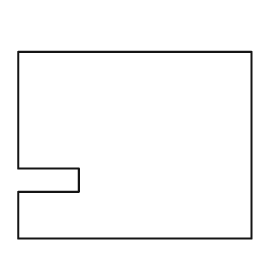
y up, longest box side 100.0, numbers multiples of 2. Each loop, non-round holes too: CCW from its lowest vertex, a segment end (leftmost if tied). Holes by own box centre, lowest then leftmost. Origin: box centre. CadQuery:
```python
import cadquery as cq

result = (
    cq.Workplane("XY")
    .moveTo(-50.0, -40.0)
    .lineTo(50.0, -40.0)
    .lineTo(50.0, 40.0)
    .lineTo(-50.0, 40.0)
    .lineTo(-50.0, -10.0)
    .lineTo(-24.0, -10.0)
    .lineTo(-24.0, -20.0)
    .lineTo(-50.0, -20.0)
    .close()
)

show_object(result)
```